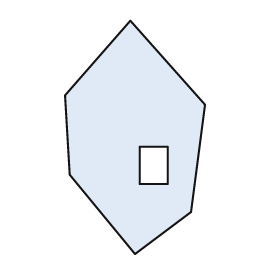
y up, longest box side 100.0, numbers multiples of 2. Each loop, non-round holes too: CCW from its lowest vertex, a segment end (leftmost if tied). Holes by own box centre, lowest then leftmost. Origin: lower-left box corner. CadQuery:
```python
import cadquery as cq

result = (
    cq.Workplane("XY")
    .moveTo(30.0, 0.0)
    .lineTo(54.0, 18.0)
    .lineTo(60.0, 64.0)
    .lineTo(28.0, 100.0)
    .lineTo(0.0, 68.0)
    .lineTo(2.0, 34.0)
    .close()
    .moveTo(32.0, 30.0)
    .lineTo(44.0, 30.0)
    .lineTo(44.0, 46.0)
    .lineTo(32.0, 46.0)
    .close()
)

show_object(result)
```